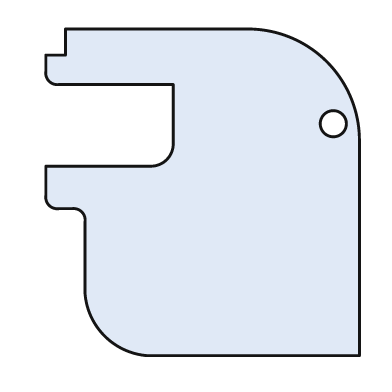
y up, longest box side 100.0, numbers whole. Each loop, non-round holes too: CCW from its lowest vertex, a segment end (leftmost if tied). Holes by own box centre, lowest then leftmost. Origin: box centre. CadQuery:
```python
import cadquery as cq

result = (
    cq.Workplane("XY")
    .moveTo(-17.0, -50.0)
    .lineTo(48.0, -50.0)
    .lineTo(48.0, 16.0)
    .threePointArc((38.0, 40.0), (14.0, 50.0))
    .lineTo(-42.0, 50.0)
    .lineTo(-42.0, 42.0)
    .lineTo(-48.0, 42.0)
    .lineTo(-48.0, 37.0)
    .threePointArc((-47.0, 34.0), (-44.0, 33.0))
    .lineTo(-9.0, 33.0)
    .lineTo(-9.0, 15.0)
    .threePointArc((-11.0, 10.0), (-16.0, 8.0))
    .lineTo(-48.0, 8.0)
    .lineTo(-48.0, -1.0)
    .threePointArc((-47.0, -4.0), (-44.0, -5.0))
    .lineTo(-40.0, -5.0)
    .threePointArc((-37.0, -6.0), (-36.0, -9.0))
    .lineTo(-36.0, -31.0)
    .threePointArc((-30.0, -44.0), (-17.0, -50.0))
    .close()
    .moveTo(40.0, 21.0)
    .circle(4.0)
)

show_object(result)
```